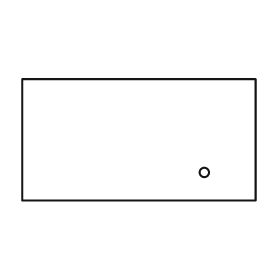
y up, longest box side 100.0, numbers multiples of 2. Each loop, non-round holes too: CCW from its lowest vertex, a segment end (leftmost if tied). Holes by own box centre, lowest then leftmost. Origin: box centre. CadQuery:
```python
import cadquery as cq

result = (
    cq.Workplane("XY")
    .moveTo(-50.0, -26.0)
    .lineTo(50.0, -26.0)
    .lineTo(50.0, 26.0)
    .lineTo(-50.0, 26.0)
    .close()
    .moveTo(28.0, -14.0)
    .circle(2.0)
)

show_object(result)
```